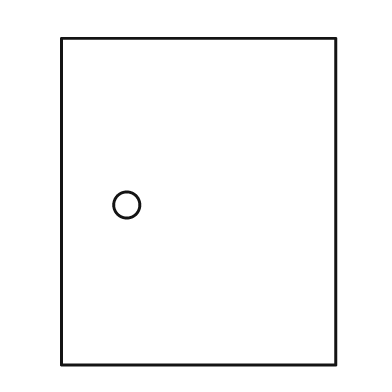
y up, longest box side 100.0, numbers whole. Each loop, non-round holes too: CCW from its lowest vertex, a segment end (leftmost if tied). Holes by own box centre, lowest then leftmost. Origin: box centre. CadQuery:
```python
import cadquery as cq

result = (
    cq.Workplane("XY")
    .moveTo(-42.0, -50.0)
    .lineTo(42.0, -50.0)
    .lineTo(42.0, 50.0)
    .lineTo(-42.0, 50.0)
    .close()
    .moveTo(-22.0, -1.0)
    .circle(4.0)
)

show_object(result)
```